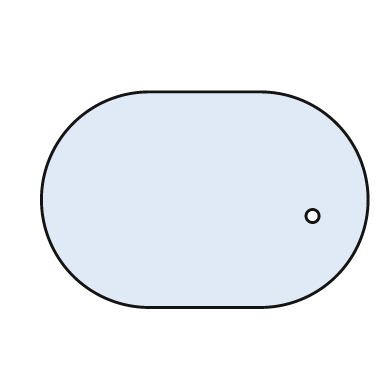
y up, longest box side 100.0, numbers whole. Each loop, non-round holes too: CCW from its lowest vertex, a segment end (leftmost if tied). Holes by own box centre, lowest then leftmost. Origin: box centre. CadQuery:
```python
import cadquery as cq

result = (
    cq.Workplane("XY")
    .moveTo(-17.0, -33.0)
    .lineTo(17.0, -33.0)
    .threePointArc((50.0, 0.0), (17.0, 33.0))
    .lineTo(-17.0, 33.0)
    .threePointArc((-50.0, 0.0), (-17.0, -33.0))
    .close()
    .moveTo(33.0, -5.0)
    .circle(2.0)
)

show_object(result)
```